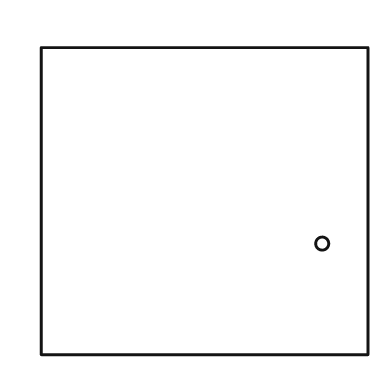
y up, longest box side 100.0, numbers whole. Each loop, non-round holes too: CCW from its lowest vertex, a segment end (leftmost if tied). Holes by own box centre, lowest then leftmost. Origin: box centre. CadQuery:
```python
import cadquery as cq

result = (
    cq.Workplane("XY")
    .moveTo(-50.0, -47.0)
    .lineTo(50.0, -47.0)
    .lineTo(50.0, 47.0)
    .lineTo(-50.0, 47.0)
    .close()
    .moveTo(36.0, -13.0)
    .circle(2.0)
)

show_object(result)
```